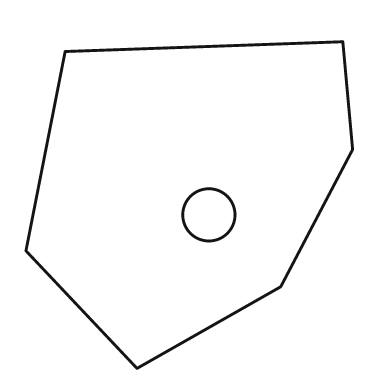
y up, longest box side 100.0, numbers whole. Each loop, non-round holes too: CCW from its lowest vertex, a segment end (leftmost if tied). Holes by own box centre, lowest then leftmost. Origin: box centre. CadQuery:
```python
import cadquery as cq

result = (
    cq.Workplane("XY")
    .moveTo(-16.0, -50.0)
    .lineTo(28.0, -25.0)
    .lineTo(50.0, 17.0)
    .lineTo(47.0, 50.0)
    .lineTo(-38.0, 47.0)
    .lineTo(-50.0, -14.0)
    .close()
    .moveTo(6.0, -3.0)
    .circle(8.0)
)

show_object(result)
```